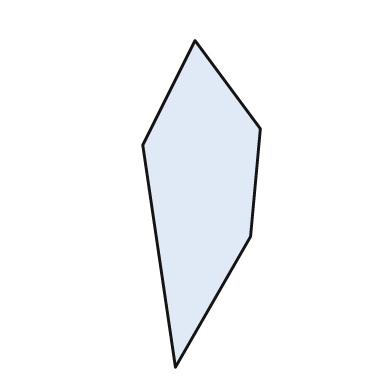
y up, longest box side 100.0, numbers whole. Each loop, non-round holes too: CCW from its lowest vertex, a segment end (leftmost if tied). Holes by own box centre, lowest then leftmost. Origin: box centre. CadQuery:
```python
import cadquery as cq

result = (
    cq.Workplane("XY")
    .moveTo(-8.0, -50.0)
    .lineTo(15.0, -10.0)
    .lineTo(18.0, 23.0)
    .lineTo(-2.0, 50.0)
    .lineTo(-18.0, 18.0)
    .close()
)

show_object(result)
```